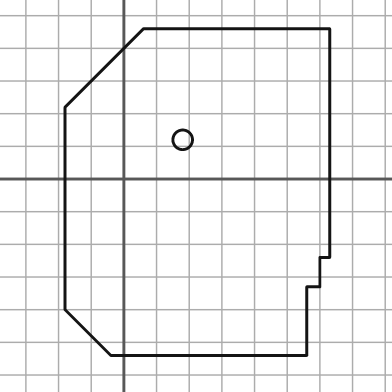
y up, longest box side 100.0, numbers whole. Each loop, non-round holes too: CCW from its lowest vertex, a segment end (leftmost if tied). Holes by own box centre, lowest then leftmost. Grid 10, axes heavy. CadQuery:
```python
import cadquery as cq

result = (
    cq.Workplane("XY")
    .moveTo(-4.0, -54.0)
    .lineTo(56.0, -54.0)
    .lineTo(56.0, -33.0)
    .lineTo(60.0, -33.0)
    .lineTo(60.0, -24.0)
    .lineTo(63.0, -24.0)
    .lineTo(63.0, 46.0)
    .lineTo(6.0, 46.0)
    .lineTo(-18.0, 22.0)
    .lineTo(-18.0, -40.0)
    .close()
    .moveTo(18.0, 12.0)
    .circle(3.0)
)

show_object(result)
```